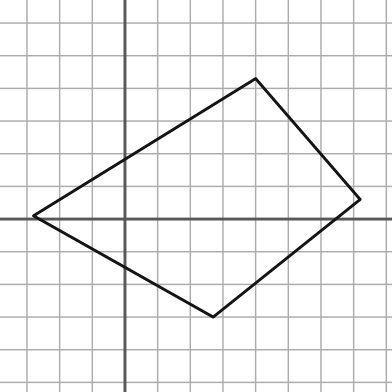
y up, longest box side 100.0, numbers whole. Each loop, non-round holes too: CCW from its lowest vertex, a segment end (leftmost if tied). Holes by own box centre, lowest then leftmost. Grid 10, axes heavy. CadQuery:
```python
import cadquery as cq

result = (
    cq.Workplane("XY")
    .moveTo(27.0, -30.0)
    .lineTo(72.0, 6.0)
    .lineTo(40.0, 43.0)
    .lineTo(-28.0, 1.0)
    .close()
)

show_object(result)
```